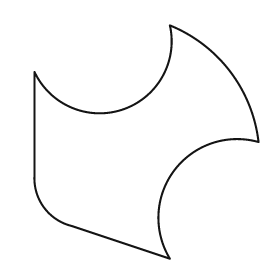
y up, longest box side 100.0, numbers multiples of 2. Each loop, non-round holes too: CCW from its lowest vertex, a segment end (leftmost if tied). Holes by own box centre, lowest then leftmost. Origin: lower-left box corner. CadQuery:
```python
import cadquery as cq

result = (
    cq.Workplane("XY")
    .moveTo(58.0, 0.0)
    .threePointArc((60.0, 38.0), (96.0, 50.0))
    .threePointArc((84.0, 80.0), (58.0, 100.0))
    .threePointArc((38.0, 64.0), (0.0, 80.0))
    .lineTo(0.0, 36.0)
    .threePointArc((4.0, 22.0), (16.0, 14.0))
    .close()
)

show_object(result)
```